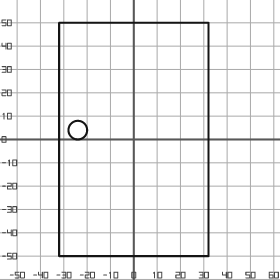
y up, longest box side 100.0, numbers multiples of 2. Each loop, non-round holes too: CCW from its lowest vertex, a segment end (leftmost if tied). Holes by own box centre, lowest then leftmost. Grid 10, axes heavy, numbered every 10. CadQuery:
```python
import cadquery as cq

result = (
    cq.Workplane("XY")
    .moveTo(-32.0, -50.0)
    .lineTo(32.0, -50.0)
    .lineTo(32.0, 50.0)
    .lineTo(-32.0, 50.0)
    .close()
    .moveTo(-24.0, 4.0)
    .circle(4.0)
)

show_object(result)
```